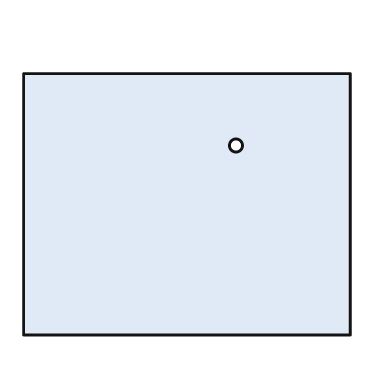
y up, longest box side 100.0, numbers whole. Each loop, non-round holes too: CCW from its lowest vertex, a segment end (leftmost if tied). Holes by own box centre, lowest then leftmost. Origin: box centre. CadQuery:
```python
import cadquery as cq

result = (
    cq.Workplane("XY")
    .moveTo(-50.0, -40.0)
    .lineTo(50.0, -40.0)
    .lineTo(50.0, 40.0)
    .lineTo(-50.0, 40.0)
    .close()
    .moveTo(15.0, 18.0)
    .circle(2.0)
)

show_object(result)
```